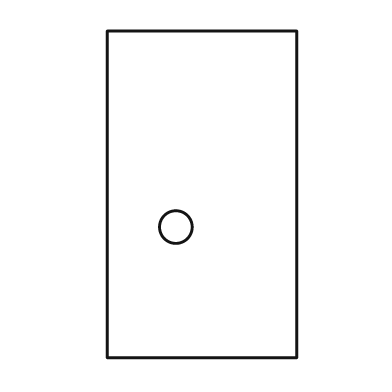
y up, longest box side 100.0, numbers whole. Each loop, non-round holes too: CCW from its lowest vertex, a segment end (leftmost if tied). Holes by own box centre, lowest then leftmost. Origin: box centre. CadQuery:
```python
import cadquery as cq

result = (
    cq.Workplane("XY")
    .moveTo(-29.0, -50.0)
    .lineTo(29.0, -50.0)
    .lineTo(29.0, 50.0)
    .lineTo(-29.0, 50.0)
    .close()
    .moveTo(-8.0, -10.0)
    .circle(5.0)
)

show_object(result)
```